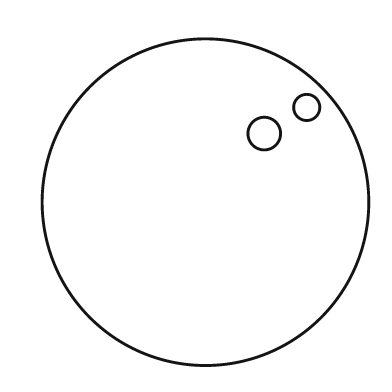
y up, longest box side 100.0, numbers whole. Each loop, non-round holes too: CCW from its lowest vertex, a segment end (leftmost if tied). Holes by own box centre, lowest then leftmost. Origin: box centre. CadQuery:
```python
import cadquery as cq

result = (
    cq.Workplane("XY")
    .moveTo(0.0, 0.0)
    .circle(50.0)
    .moveTo(18.0, 21.0)
    .circle(5.0)
    .moveTo(31.0, 29.0)
    .circle(4.0)
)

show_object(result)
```